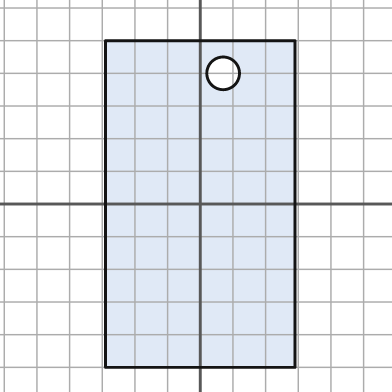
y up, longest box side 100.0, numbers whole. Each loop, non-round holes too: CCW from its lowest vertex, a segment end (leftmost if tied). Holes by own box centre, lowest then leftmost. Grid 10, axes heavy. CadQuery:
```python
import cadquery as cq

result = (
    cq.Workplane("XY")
    .moveTo(-29.0, -50.0)
    .lineTo(29.0, -50.0)
    .lineTo(29.0, 50.0)
    .lineTo(-29.0, 50.0)
    .close()
    .moveTo(7.0, 40.0)
    .circle(5.0)
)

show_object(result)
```